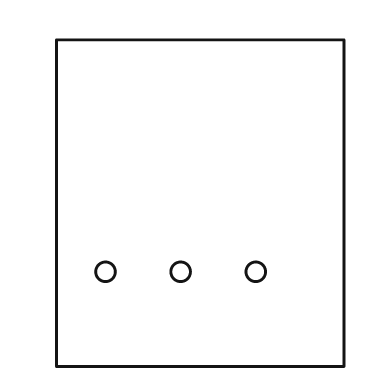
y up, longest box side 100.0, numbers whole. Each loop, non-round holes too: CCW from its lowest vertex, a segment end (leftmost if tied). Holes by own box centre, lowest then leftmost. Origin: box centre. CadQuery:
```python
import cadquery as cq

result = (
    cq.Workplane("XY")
    .moveTo(-44.0, -50.0)
    .lineTo(44.0, -50.0)
    .lineTo(44.0, 50.0)
    .lineTo(-44.0, 50.0)
    .close()
    .moveTo(-29.0, -21.0)
    .circle(3.0)
    .moveTo(-6.0, -21.0)
    .circle(3.0)
    .moveTo(17.0, -21.0)
    .circle(3.0)
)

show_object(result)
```